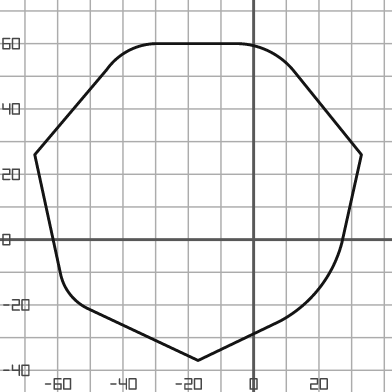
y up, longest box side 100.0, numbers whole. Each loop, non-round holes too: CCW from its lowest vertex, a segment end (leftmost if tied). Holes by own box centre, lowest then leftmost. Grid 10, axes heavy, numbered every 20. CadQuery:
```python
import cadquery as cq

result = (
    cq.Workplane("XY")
    .moveTo(-17.0, -37.0)
    .lineTo(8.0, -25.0)
    .threePointArc((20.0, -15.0), (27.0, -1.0))
    .lineTo(33.0, 26.0)
    .lineTo(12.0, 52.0)
    .threePointArc((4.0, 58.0), (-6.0, 60.0))
    .lineTo(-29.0, 60.0)
    .threePointArc((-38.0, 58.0), (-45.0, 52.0))
    .lineTo(-67.0, 26.0)
    .lineTo(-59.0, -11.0)
    .threePointArc((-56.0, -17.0), (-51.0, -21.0))
    .close()
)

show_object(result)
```